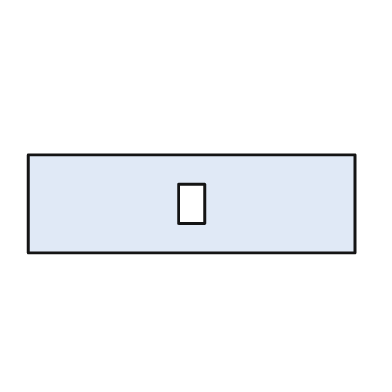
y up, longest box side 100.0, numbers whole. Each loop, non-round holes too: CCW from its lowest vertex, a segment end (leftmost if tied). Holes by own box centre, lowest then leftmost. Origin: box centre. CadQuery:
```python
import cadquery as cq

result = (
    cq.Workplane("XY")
    .moveTo(-50.0, -15.0)
    .lineTo(50.0, -15.0)
    .lineTo(50.0, 15.0)
    .lineTo(-50.0, 15.0)
    .close()
    .moveTo(-4.0, -6.0)
    .lineTo(4.0, -6.0)
    .lineTo(4.0, 6.0)
    .lineTo(-4.0, 6.0)
    .close()
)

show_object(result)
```